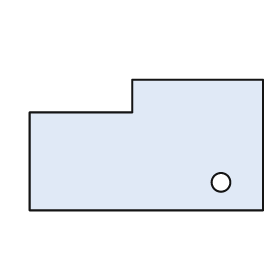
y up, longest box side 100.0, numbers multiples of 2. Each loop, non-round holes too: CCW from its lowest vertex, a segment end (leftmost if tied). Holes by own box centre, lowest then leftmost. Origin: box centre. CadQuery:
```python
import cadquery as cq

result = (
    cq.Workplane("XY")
    .moveTo(-50.0, -28.0)
    .lineTo(50.0, -28.0)
    .lineTo(50.0, 28.0)
    .lineTo(-6.0, 28.0)
    .lineTo(-6.0, 14.0)
    .lineTo(-50.0, 14.0)
    .close()
    .moveTo(32.0, -16.0)
    .circle(4.0)
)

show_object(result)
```